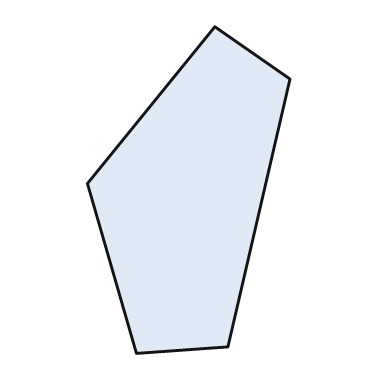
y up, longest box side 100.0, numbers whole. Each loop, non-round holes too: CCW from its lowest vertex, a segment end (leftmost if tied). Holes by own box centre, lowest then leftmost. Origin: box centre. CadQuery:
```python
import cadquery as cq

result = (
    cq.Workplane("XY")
    .moveTo(-16.0, -50.0)
    .lineTo(12.0, -48.0)
    .lineTo(31.0, 34.0)
    .lineTo(8.0, 50.0)
    .lineTo(-31.0, 2.0)
    .close()
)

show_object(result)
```